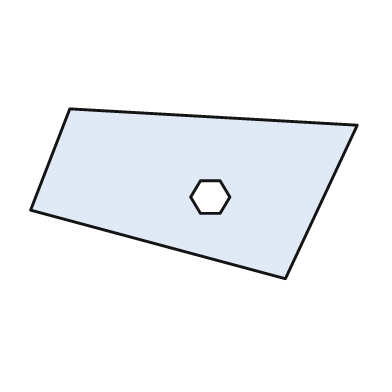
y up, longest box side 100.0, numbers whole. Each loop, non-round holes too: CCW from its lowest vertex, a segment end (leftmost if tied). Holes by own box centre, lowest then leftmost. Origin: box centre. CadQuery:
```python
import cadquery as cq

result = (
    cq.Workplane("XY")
    .moveTo(28.0, -26.0)
    .lineTo(50.0, 21.0)
    .lineTo(-38.0, 26.0)
    .lineTo(-50.0, -5.0)
    .close()
    .moveTo(2.0, -6.0)
    .lineTo(8.0, -6.0)
    .lineTo(11.0, -1.0)
    .lineTo(8.0, 4.0)
    .lineTo(2.0, 4.0)
    .lineTo(-1.0, -1.0)
    .close()
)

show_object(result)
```